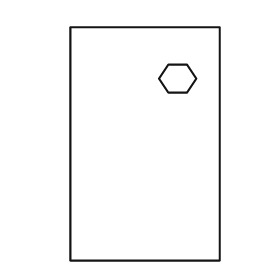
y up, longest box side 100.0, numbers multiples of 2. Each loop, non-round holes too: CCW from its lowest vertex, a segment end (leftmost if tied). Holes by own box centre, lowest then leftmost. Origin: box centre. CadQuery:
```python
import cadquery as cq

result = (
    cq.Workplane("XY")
    .moveTo(-32.0, -50.0)
    .lineTo(32.0, -50.0)
    .lineTo(32.0, 50.0)
    .lineTo(-32.0, 50.0)
    .close()
    .moveTo(10.0, 22.0)
    .lineTo(18.0, 22.0)
    .lineTo(22.0, 28.0)
    .lineTo(18.0, 34.0)
    .lineTo(10.0, 34.0)
    .lineTo(6.0, 28.0)
    .close()
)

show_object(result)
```